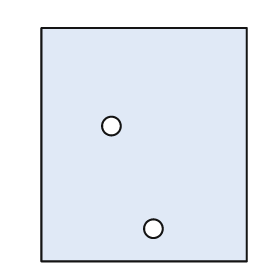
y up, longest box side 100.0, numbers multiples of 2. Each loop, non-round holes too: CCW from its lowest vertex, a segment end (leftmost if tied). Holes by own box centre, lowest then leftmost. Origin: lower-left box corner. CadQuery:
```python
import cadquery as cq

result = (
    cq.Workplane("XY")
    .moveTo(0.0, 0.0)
    .lineTo(88.0, 0.0)
    .lineTo(88.0, 100.0)
    .lineTo(0.0, 100.0)
    .close()
    .moveTo(48.0, 14.0)
    .circle(4.0)
    .moveTo(30.0, 58.0)
    .circle(4.0)
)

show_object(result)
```